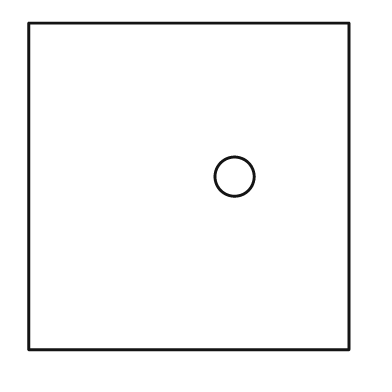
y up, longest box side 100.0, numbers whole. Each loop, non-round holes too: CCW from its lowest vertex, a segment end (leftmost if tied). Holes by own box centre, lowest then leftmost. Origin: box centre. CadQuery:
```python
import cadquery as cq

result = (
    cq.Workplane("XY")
    .moveTo(-49.0, -50.0)
    .lineTo(49.0, -50.0)
    .lineTo(49.0, 50.0)
    .lineTo(-49.0, 50.0)
    .close()
    .moveTo(14.0, 3.0)
    .circle(6.0)
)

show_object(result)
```